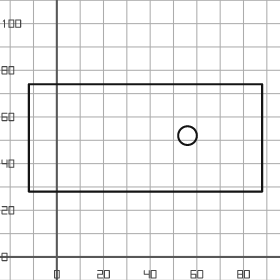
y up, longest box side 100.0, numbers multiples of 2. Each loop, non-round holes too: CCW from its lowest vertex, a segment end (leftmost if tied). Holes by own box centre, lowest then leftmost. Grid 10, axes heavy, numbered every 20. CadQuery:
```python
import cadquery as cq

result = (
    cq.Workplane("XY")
    .moveTo(-12.0, 28.0)
    .lineTo(88.0, 28.0)
    .lineTo(88.0, 74.0)
    .lineTo(-12.0, 74.0)
    .close()
    .moveTo(56.0, 52.0)
    .circle(4.0)
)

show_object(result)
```